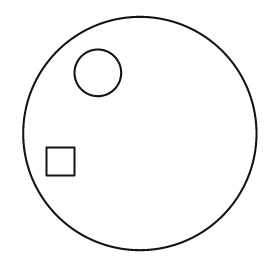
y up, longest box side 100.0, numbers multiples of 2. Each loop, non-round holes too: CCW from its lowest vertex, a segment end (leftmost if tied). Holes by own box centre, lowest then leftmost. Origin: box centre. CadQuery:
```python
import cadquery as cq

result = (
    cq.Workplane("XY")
    .moveTo(0.0, 0.0)
    .circle(50.0)
    .moveTo(-40.0, -18.0)
    .lineTo(-28.0, -18.0)
    .lineTo(-28.0, -6.0)
    .lineTo(-40.0, -6.0)
    .close()
    .moveTo(-18.0, 26.0)
    .circle(10.0)
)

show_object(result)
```